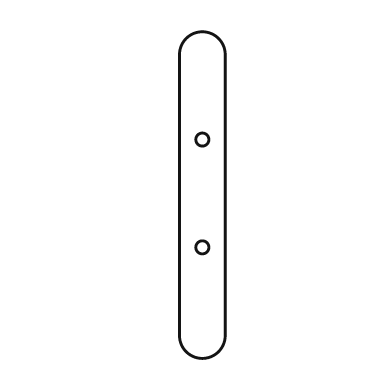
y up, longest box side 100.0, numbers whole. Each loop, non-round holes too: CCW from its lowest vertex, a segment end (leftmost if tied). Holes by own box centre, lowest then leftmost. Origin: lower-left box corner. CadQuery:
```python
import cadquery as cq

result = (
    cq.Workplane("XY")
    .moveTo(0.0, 7.0)
    .threePointArc((7.0, 0.0), (14.0, 7.0))
    .lineTo(14.0, 93.0)
    .threePointArc((7.0, 100.0), (0.0, 93.0))
    .close()
    .moveTo(7.0, 34.0)
    .circle(2.0)
    .moveTo(7.0, 67.0)
    .circle(2.0)
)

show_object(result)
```